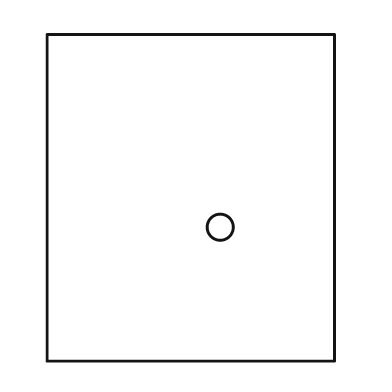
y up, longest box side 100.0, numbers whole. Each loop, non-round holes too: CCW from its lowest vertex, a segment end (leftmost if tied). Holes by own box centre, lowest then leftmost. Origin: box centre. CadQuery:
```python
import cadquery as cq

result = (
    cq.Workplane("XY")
    .moveTo(-44.0, -50.0)
    .lineTo(44.0, -50.0)
    .lineTo(44.0, 50.0)
    .lineTo(-44.0, 50.0)
    .close()
    .moveTo(9.0, -9.0)
    .circle(4.0)
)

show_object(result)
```